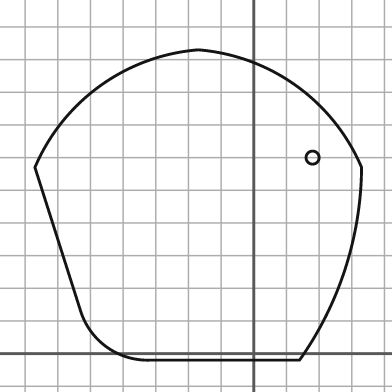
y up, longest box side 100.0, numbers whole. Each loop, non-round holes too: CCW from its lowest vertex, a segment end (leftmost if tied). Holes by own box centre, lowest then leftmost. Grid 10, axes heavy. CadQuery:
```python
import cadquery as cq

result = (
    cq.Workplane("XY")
    .moveTo(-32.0, -2.0)
    .lineTo(14.0, -2.0)
    .threePointArc((28.0, 26.0), (33.0, 57.0))
    .threePointArc((13.0, 82.0), (-17.0, 93.0))
    .threePointArc((-47.0, 82.0), (-67.0, 57.0))
    .lineTo(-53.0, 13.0)
    .threePointArc((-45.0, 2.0), (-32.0, -2.0))
    .close()
    .moveTo(18.0, 60.0)
    .circle(2.0)
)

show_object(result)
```